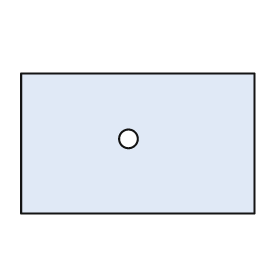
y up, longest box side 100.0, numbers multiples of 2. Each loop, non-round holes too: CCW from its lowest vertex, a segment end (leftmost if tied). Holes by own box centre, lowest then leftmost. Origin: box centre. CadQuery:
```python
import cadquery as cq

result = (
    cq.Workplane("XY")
    .moveTo(-50.0, -30.0)
    .lineTo(50.0, -30.0)
    .lineTo(50.0, 30.0)
    .lineTo(-50.0, 30.0)
    .close()
    .moveTo(-4.0, 2.0)
    .circle(4.0)
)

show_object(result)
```